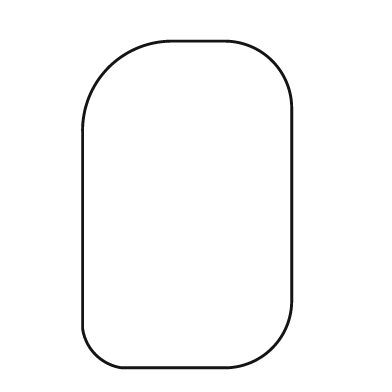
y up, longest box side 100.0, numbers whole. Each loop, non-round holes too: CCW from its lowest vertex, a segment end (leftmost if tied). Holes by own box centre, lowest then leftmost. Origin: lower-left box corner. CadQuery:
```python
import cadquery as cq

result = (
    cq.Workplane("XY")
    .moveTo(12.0, 0.0)
    .lineTo(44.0, 0.0)
    .threePointArc((58.0, 6.0), (64.0, 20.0))
    .lineTo(64.0, 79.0)
    .threePointArc((58.0, 94.0), (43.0, 100.0))
    .lineTo(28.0, 100.0)
    .threePointArc((8.0, 92.0), (0.0, 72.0))
    .lineTo(0.0, 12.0)
    .threePointArc((4.0, 4.0), (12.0, 0.0))
    .close()
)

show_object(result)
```